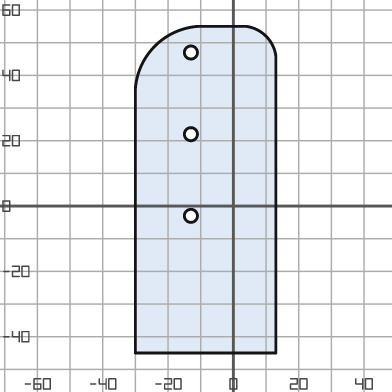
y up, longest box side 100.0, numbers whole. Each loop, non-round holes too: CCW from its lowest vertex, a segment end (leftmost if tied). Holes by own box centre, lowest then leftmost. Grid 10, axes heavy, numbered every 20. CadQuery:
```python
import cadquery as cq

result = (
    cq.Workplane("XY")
    .moveTo(-30.0, -45.0)
    .lineTo(13.0, -45.0)
    .lineTo(13.0, 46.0)
    .threePointArc((10.0, 52.0), (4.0, 55.0))
    .lineTo(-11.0, 55.0)
    .threePointArc((-24.0, 49.0), (-30.0, 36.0))
    .close()
    .moveTo(-13.0, -3.0)
    .circle(2.0)
    .moveTo(-13.0, 22.0)
    .circle(2.0)
    .moveTo(-13.0, 47.0)
    .circle(2.0)
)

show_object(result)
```